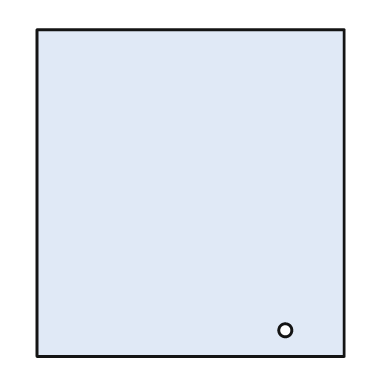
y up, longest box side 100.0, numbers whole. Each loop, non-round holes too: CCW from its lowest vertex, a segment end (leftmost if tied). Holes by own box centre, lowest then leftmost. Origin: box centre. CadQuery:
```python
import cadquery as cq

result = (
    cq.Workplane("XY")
    .moveTo(-47.0, -50.0)
    .lineTo(47.0, -50.0)
    .lineTo(47.0, 50.0)
    .lineTo(-47.0, 50.0)
    .close()
    .moveTo(29.0, -42.0)
    .circle(2.0)
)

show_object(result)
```